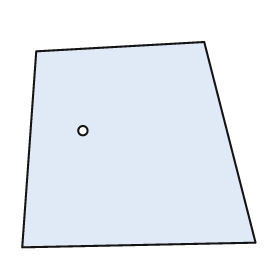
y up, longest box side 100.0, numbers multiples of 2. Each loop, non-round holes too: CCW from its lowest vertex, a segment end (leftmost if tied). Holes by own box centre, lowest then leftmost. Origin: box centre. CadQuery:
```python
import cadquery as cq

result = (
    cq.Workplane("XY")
    .moveTo(-50.0, -44.0)
    .lineTo(50.0, -42.0)
    .lineTo(28.0, 44.0)
    .lineTo(-44.0, 40.0)
    .close()
    .moveTo(-24.0, 6.0)
    .circle(2.0)
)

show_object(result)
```